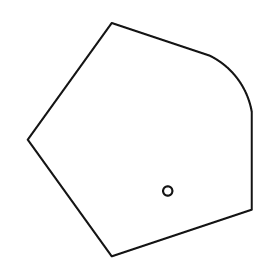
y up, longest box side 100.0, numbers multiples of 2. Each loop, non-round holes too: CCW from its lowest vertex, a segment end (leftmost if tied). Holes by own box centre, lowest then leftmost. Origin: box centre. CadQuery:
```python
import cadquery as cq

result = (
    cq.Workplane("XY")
    .moveTo(-12.0, -50.0)
    .lineTo(48.0, -30.0)
    .lineTo(48.0, 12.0)
    .threePointArc((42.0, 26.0), (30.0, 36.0))
    .lineTo(-12.0, 50.0)
    .lineTo(-48.0, 0.0)
    .close()
    .moveTo(12.0, -22.0)
    .circle(2.0)
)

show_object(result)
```